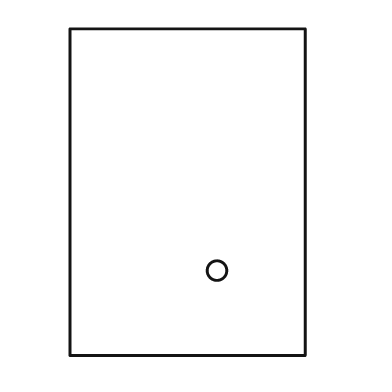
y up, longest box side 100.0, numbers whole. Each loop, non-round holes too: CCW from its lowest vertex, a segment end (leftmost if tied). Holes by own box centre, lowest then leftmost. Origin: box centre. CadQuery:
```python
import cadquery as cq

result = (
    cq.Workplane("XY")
    .moveTo(-36.0, -50.0)
    .lineTo(36.0, -50.0)
    .lineTo(36.0, 50.0)
    .lineTo(-36.0, 50.0)
    .close()
    .moveTo(9.0, -24.0)
    .circle(3.0)
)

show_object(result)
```